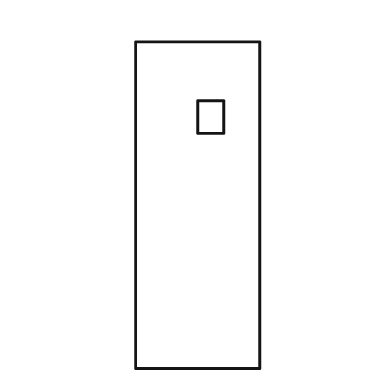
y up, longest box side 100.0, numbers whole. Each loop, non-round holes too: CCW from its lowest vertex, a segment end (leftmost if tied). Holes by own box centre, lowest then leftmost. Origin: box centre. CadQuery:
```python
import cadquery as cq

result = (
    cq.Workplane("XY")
    .moveTo(-19.0, -50.0)
    .lineTo(19.0, -50.0)
    .lineTo(19.0, 50.0)
    .lineTo(-19.0, 50.0)
    .close()
    .moveTo(0.0, 22.0)
    .lineTo(8.0, 22.0)
    .lineTo(8.0, 32.0)
    .lineTo(0.0, 32.0)
    .close()
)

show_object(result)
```